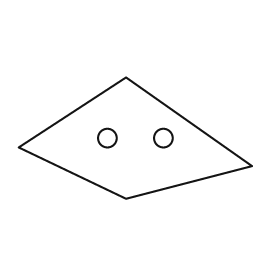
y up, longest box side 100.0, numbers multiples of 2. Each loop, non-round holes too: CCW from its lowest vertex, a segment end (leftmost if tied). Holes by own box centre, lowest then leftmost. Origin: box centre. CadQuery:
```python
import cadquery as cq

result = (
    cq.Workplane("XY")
    .moveTo(-4.0, -26.0)
    .lineTo(50.0, -12.0)
    .lineTo(-4.0, 26.0)
    .lineTo(-50.0, -4.0)
    .close()
    .moveTo(-12.0, 0.0)
    .circle(4.0)
    .moveTo(12.0, 0.0)
    .circle(4.0)
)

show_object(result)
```